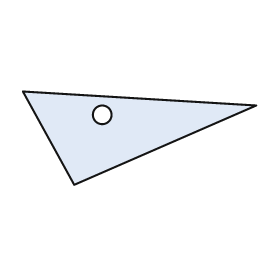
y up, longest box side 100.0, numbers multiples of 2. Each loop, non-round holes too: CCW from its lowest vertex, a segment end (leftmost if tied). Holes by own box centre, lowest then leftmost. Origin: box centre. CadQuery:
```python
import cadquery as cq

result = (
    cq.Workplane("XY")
    .moveTo(-28.0, -20.0)
    .lineTo(50.0, 14.0)
    .lineTo(-50.0, 20.0)
    .close()
    .moveTo(-16.0, 10.0)
    .circle(4.0)
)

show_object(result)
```